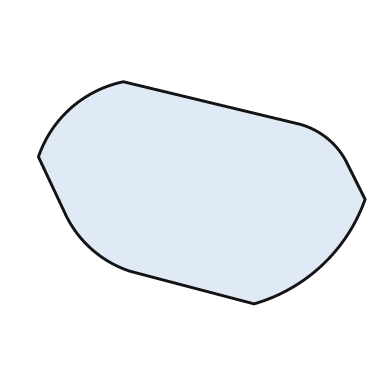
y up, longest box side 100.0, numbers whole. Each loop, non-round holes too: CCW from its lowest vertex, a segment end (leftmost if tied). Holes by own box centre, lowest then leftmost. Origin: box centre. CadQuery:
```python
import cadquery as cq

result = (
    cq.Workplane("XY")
    .moveTo(16.0, -34.0)
    .threePointArc((37.0, -22.0), (50.0, -2.0))
    .lineTo(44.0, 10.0)
    .threePointArc((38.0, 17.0), (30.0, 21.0))
    .lineTo(-24.0, 34.0)
    .threePointArc((-40.0, 26.0), (-50.0, 11.0))
    .lineTo(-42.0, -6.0)
    .threePointArc((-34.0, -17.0), (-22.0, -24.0))
    .close()
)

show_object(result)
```